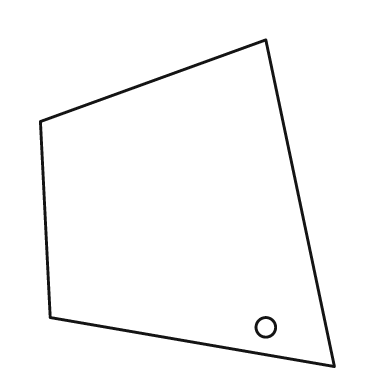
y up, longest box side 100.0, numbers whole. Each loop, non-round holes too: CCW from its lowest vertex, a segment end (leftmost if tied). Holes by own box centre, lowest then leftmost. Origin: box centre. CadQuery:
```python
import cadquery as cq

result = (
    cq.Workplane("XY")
    .moveTo(45.0, -50.0)
    .lineTo(24.0, 50.0)
    .lineTo(-45.0, 25.0)
    .lineTo(-42.0, -35.0)
    .close()
    .moveTo(24.0, -38.0)
    .circle(3.0)
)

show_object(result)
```